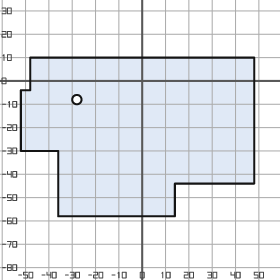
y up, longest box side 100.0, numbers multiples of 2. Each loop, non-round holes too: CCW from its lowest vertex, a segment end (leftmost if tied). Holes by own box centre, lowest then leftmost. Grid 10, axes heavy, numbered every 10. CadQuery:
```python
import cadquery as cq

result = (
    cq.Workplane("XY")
    .moveTo(-36.0, -58.0)
    .lineTo(14.0, -58.0)
    .lineTo(14.0, -44.0)
    .lineTo(48.0, -44.0)
    .lineTo(48.0, 10.0)
    .lineTo(-48.0, 10.0)
    .lineTo(-48.0, -4.0)
    .lineTo(-52.0, -4.0)
    .lineTo(-52.0, -30.0)
    .lineTo(-36.0, -30.0)
    .close()
    .moveTo(-28.0, -8.0)
    .circle(2.0)
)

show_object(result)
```